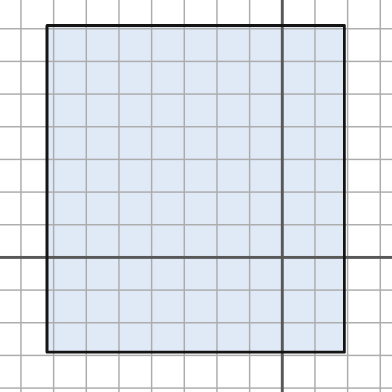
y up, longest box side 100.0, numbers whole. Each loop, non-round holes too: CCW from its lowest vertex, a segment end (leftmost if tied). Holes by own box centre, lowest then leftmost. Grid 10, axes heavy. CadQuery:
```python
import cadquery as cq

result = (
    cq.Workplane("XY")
    .moveTo(-72.0, -29.0)
    .lineTo(19.0, -29.0)
    .lineTo(19.0, 71.0)
    .lineTo(-72.0, 71.0)
    .close()
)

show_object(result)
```